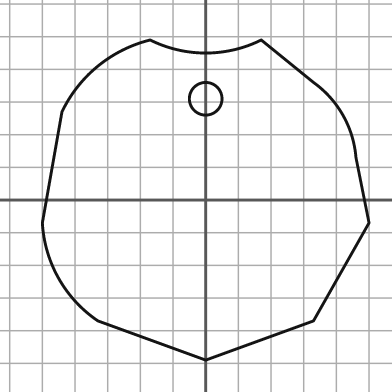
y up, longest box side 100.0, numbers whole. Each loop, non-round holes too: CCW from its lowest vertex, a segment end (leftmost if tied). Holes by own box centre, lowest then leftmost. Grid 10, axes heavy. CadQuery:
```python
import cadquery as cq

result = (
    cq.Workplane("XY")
    .moveTo(0.0, -49.0)
    .lineTo(33.0, -37.0)
    .lineTo(50.0, -7.0)
    .lineTo(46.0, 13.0)
    .threePointArc((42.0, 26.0), (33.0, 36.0))
    .lineTo(17.0, 49.0)
    .threePointArc((0.0, 45.0), (-17.0, 49.0))
    .threePointArc((-33.0, 41.0), (-44.0, 27.0))
    .lineTo(-50.0, -7.0)
    .threePointArc((-45.0, -24.0), (-33.0, -37.0))
    .close()
    .moveTo(0.0, 31.0)
    .circle(5.0)
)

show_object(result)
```